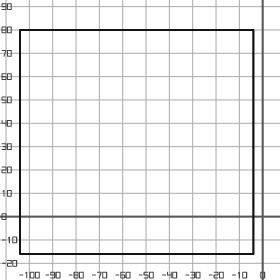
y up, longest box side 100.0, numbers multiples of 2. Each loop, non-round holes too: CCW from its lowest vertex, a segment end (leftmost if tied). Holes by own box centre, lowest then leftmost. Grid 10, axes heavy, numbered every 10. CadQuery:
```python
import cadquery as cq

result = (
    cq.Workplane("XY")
    .moveTo(-104.0, -16.0)
    .lineTo(-4.0, -16.0)
    .lineTo(-4.0, 80.0)
    .lineTo(-104.0, 80.0)
    .close()
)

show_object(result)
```